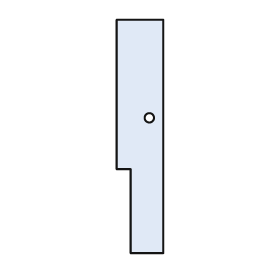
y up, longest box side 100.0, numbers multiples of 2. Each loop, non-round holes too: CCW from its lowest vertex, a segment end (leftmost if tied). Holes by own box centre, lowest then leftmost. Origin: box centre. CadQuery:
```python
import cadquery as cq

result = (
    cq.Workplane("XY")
    .moveTo(-4.0, -50.0)
    .lineTo(10.0, -50.0)
    .lineTo(10.0, 50.0)
    .lineTo(-10.0, 50.0)
    .lineTo(-10.0, -14.0)
    .lineTo(-4.0, -14.0)
    .close()
    .moveTo(4.0, 8.0)
    .circle(2.0)
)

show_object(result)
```